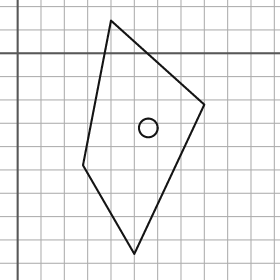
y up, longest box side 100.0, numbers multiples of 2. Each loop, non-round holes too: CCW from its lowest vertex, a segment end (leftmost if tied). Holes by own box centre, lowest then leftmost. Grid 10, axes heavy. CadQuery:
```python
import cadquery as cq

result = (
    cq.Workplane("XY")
    .moveTo(50.0, -86.0)
    .lineTo(80.0, -22.0)
    .lineTo(40.0, 14.0)
    .lineTo(28.0, -48.0)
    .close()
    .moveTo(56.0, -32.0)
    .circle(4.0)
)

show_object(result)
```